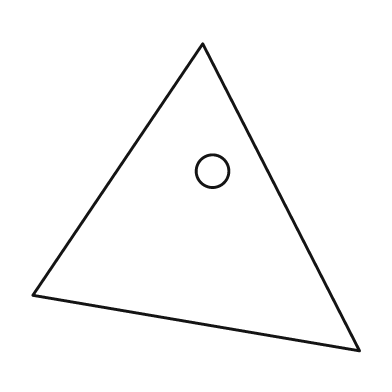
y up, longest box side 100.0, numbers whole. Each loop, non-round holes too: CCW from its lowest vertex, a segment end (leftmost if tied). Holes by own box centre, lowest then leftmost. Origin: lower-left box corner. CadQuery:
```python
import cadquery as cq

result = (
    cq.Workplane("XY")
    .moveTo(100.0, 0.0)
    .lineTo(52.0, 94.0)
    .lineTo(0.0, 17.0)
    .close()
    .moveTo(55.0, 55.0)
    .circle(5.0)
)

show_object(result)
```